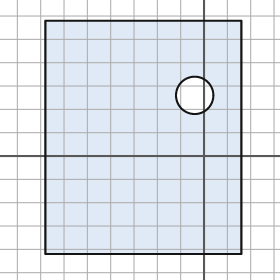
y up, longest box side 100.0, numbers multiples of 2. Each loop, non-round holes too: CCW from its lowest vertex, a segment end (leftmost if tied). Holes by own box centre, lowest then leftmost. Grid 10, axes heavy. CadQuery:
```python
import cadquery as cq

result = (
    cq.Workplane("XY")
    .moveTo(-68.0, -42.0)
    .lineTo(16.0, -42.0)
    .lineTo(16.0, 58.0)
    .lineTo(-68.0, 58.0)
    .close()
    .moveTo(-4.0, 26.0)
    .circle(8.0)
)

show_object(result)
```